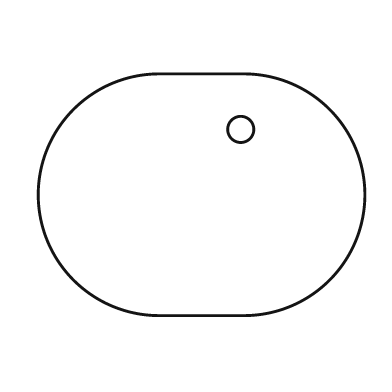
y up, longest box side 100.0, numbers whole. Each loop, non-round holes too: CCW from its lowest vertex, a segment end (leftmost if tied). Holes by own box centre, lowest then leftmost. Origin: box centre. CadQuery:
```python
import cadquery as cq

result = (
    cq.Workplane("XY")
    .moveTo(-13.0, -37.0)
    .lineTo(13.0, -37.0)
    .threePointArc((50.0, 0.0), (13.0, 37.0))
    .lineTo(-13.0, 37.0)
    .threePointArc((-50.0, 0.0), (-13.0, -37.0))
    .close()
    .moveTo(12.0, 20.0)
    .circle(4.0)
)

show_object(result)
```